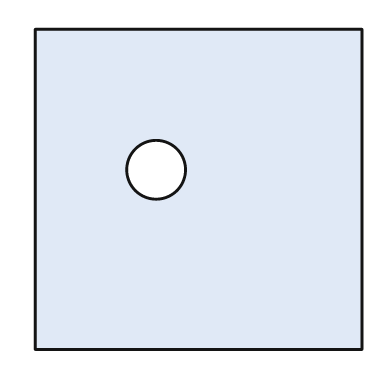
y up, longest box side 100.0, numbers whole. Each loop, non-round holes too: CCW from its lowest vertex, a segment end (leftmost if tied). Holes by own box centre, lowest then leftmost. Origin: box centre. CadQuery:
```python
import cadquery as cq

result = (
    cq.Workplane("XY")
    .moveTo(-50.0, -49.0)
    .lineTo(50.0, -49.0)
    .lineTo(50.0, 49.0)
    .lineTo(-50.0, 49.0)
    .close()
    .moveTo(-13.0, 6.0)
    .circle(9.0)
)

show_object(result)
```